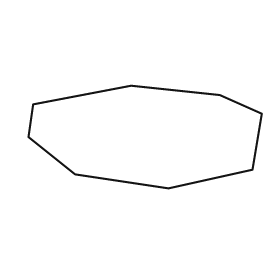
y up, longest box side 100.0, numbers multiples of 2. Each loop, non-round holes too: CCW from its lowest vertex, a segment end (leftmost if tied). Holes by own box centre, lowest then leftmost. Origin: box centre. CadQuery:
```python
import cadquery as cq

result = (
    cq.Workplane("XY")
    .moveTo(10.0, -22.0)
    .lineTo(46.0, -14.0)
    .lineTo(50.0, 10.0)
    .lineTo(32.0, 18.0)
    .lineTo(-6.0, 22.0)
    .lineTo(-48.0, 14.0)
    .lineTo(-50.0, 0.0)
    .lineTo(-30.0, -16.0)
    .close()
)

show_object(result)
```